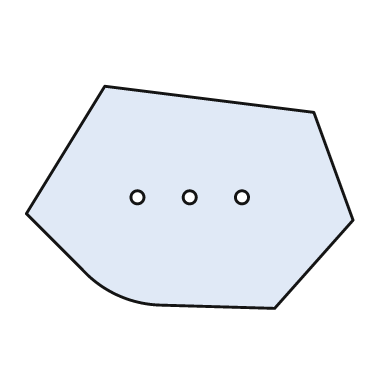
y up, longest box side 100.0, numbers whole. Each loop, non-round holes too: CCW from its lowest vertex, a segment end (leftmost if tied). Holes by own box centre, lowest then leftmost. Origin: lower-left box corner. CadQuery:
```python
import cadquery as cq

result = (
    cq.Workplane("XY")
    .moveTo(76.0, 0.0)
    .lineTo(100.0, 27.0)
    .lineTo(88.0, 60.0)
    .lineTo(24.0, 68.0)
    .lineTo(0.0, 29.0)
    .lineTo(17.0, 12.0)
    .threePointArc((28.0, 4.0), (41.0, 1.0))
    .close()
    .moveTo(34.0, 34.0)
    .circle(2.0)
    .moveTo(50.0, 34.0)
    .circle(2.0)
    .moveTo(66.0, 34.0)
    .circle(2.0)
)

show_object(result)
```